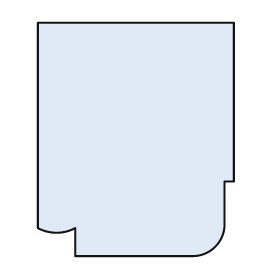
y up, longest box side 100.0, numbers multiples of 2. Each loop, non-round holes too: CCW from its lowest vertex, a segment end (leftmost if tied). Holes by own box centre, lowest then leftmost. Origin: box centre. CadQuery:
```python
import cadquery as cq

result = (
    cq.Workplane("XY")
    .moveTo(-26.0, -50.0)
    .lineTo(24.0, -50.0)
    .threePointArc((34.0, -46.0), (38.0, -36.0))
    .lineTo(38.0, -18.0)
    .lineTo(42.0, -18.0)
    .lineTo(42.0, 50.0)
    .lineTo(-42.0, 50.0)
    .lineTo(-42.0, -38.0)
    .threePointArc((-34.0, -40.0), (-26.0, -38.0))
    .close()
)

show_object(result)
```